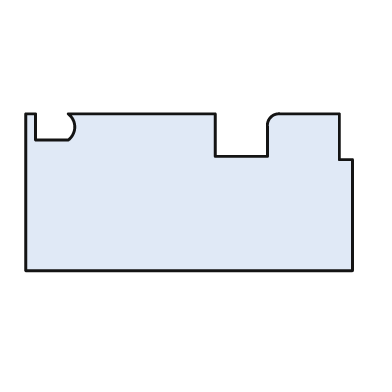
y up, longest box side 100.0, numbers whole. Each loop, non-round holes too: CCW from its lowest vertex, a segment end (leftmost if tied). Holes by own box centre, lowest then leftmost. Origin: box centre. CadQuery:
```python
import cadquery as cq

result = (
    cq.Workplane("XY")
    .moveTo(-50.0, -24.0)
    .lineTo(50.0, -24.0)
    .lineTo(50.0, 10.0)
    .lineTo(46.0, 10.0)
    .lineTo(46.0, 24.0)
    .lineTo(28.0, 24.0)
    .threePointArc((25.0, 23.0), (24.0, 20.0))
    .lineTo(24.0, 11.0)
    .lineTo(8.0, 11.0)
    .lineTo(8.0, 24.0)
    .lineTo(-37.0, 24.0)
    .threePointArc((-35.0, 20.0), (-37.0, 16.0))
    .lineTo(-47.0, 16.0)
    .lineTo(-47.0, 24.0)
    .lineTo(-50.0, 24.0)
    .close()
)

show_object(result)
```